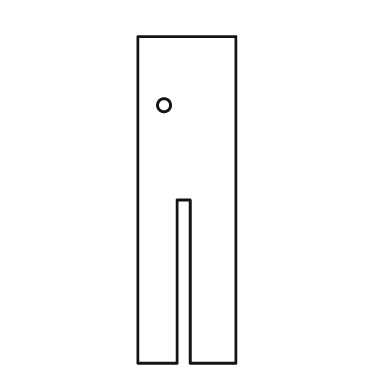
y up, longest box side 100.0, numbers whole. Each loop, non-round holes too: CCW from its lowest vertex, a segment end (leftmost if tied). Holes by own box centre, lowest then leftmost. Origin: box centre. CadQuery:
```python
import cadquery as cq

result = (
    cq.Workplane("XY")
    .moveTo(-15.0, -50.0)
    .lineTo(-3.0, -50.0)
    .lineTo(-3.0, 0.0)
    .lineTo(1.0, 0.0)
    .lineTo(1.0, -50.0)
    .lineTo(15.0, -50.0)
    .lineTo(15.0, 50.0)
    .lineTo(-15.0, 50.0)
    .close()
    .moveTo(-7.0, 29.0)
    .circle(2.0)
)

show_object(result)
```